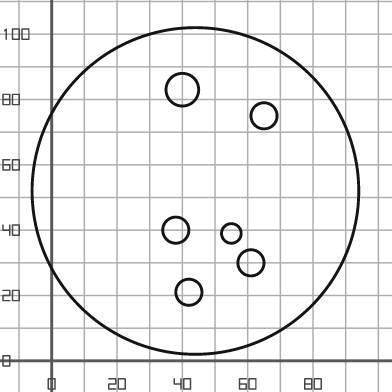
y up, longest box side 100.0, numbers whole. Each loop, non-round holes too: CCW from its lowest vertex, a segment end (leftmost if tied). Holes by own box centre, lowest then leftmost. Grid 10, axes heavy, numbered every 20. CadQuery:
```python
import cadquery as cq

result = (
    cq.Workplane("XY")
    .moveTo(44.0, 52.0)
    .circle(50.0)
    .moveTo(42.0, 21.0)
    .circle(4.0)
    .moveTo(61.0, 30.0)
    .circle(4.0)
    .moveTo(55.0, 39.0)
    .circle(3.0)
    .moveTo(38.0, 40.0)
    .circle(4.0)
    .moveTo(65.0, 75.0)
    .circle(4.0)
    .moveTo(40.0, 83.0)
    .circle(5.0)
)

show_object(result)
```